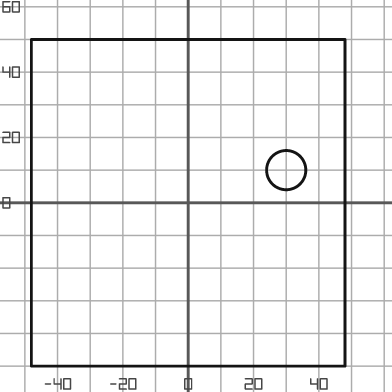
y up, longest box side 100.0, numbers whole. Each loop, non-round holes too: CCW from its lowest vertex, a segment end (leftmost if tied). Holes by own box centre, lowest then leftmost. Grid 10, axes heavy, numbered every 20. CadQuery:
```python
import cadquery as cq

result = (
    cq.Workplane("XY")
    .moveTo(-48.0, -50.0)
    .lineTo(48.0, -50.0)
    .lineTo(48.0, 50.0)
    .lineTo(-48.0, 50.0)
    .close()
    .moveTo(30.0, 10.0)
    .circle(6.0)
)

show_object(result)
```